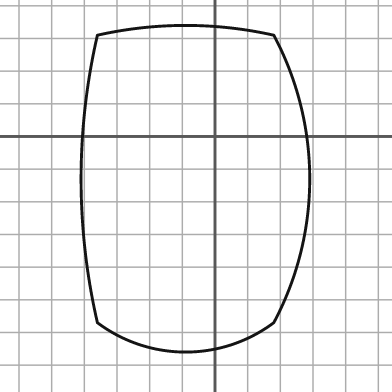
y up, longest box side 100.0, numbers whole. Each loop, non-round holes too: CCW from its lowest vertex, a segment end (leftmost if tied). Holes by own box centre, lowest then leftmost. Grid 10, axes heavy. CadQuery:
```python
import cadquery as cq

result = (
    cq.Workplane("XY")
    .moveTo(-36.0, -57.0)
    .threePointArc((-9.0, -66.0), (18.0, -57.0))
    .threePointArc((29.0, -13.0), (18.0, 31.0))
    .threePointArc((-9.0, 34.0), (-36.0, 31.0))
    .threePointArc((-41.0, -13.0), (-36.0, -57.0))
    .close()
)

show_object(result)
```